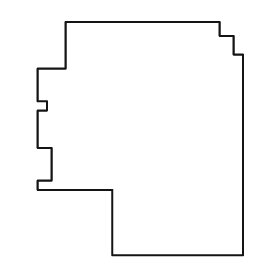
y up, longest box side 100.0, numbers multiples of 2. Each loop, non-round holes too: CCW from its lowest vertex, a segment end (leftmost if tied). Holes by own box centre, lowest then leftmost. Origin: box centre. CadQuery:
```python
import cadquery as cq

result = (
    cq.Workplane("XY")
    .moveTo(-12.0, -50.0)
    .lineTo(44.0, -50.0)
    .lineTo(44.0, 36.0)
    .lineTo(40.0, 36.0)
    .lineTo(40.0, 44.0)
    .lineTo(34.0, 44.0)
    .lineTo(34.0, 50.0)
    .lineTo(-32.0, 50.0)
    .lineTo(-32.0, 30.0)
    .lineTo(-44.0, 30.0)
    .lineTo(-44.0, 16.0)
    .lineTo(-40.0, 16.0)
    .lineTo(-40.0, 12.0)
    .lineTo(-44.0, 12.0)
    .lineTo(-44.0, -4.0)
    .lineTo(-38.0, -4.0)
    .lineTo(-38.0, -18.0)
    .lineTo(-44.0, -18.0)
    .lineTo(-44.0, -22.0)
    .lineTo(-12.0, -22.0)
    .close()
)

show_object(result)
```